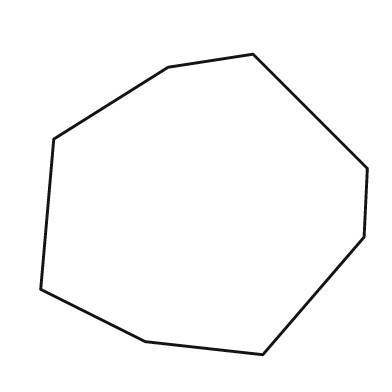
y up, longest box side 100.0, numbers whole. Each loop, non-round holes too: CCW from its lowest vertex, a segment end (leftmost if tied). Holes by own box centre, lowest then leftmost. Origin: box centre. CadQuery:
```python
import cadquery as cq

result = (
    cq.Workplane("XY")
    .moveTo(18.0, -46.0)
    .lineTo(49.0, -10.0)
    .lineTo(50.0, 11.0)
    .lineTo(15.0, 46.0)
    .lineTo(-11.0, 42.0)
    .lineTo(-46.0, 20.0)
    .lineTo(-50.0, -26.0)
    .lineTo(-18.0, -42.0)
    .close()
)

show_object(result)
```